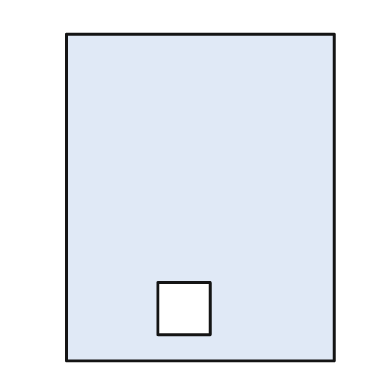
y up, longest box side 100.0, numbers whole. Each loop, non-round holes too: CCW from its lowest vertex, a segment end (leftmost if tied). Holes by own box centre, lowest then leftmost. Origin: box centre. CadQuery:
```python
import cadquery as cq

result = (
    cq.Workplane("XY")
    .moveTo(-41.0, -50.0)
    .lineTo(41.0, -50.0)
    .lineTo(41.0, 50.0)
    .lineTo(-41.0, 50.0)
    .close()
    .moveTo(-13.0, -42.0)
    .lineTo(3.0, -42.0)
    .lineTo(3.0, -26.0)
    .lineTo(-13.0, -26.0)
    .close()
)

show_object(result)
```